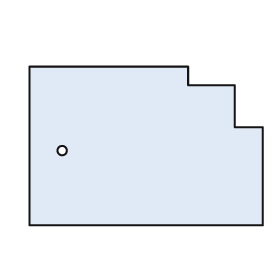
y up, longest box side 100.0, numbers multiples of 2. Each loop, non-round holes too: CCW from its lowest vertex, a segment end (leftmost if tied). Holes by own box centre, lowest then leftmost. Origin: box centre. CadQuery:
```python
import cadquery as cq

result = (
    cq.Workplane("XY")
    .moveTo(-50.0, -34.0)
    .lineTo(50.0, -34.0)
    .lineTo(50.0, 8.0)
    .lineTo(38.0, 8.0)
    .lineTo(38.0, 26.0)
    .lineTo(18.0, 26.0)
    .lineTo(18.0, 34.0)
    .lineTo(-50.0, 34.0)
    .close()
    .moveTo(-36.0, -2.0)
    .circle(2.0)
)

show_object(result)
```